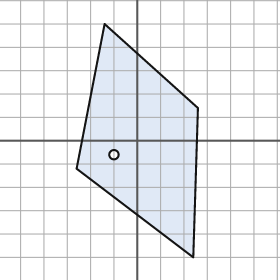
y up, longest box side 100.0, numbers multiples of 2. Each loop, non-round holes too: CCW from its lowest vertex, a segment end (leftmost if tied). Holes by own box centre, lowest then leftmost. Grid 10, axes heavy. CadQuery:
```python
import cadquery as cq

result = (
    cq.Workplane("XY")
    .moveTo(24.0, -50.0)
    .lineTo(26.0, 14.0)
    .lineTo(-14.0, 50.0)
    .lineTo(-26.0, -12.0)
    .close()
    .moveTo(-10.0, -6.0)
    .circle(2.0)
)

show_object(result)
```